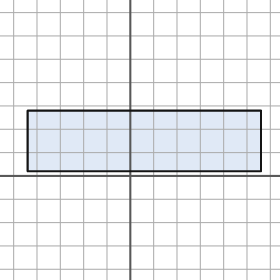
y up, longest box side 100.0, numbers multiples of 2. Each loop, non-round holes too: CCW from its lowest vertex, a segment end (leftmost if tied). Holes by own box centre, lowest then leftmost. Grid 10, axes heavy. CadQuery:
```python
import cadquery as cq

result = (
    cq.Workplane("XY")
    .moveTo(-44.0, 2.0)
    .lineTo(56.0, 2.0)
    .lineTo(56.0, 28.0)
    .lineTo(-44.0, 28.0)
    .close()
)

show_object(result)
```